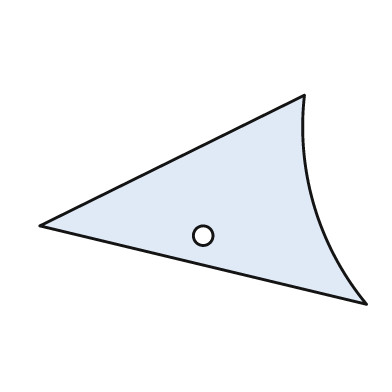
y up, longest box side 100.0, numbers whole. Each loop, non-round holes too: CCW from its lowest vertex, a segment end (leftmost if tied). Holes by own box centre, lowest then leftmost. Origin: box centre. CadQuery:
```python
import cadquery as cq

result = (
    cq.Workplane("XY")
    .moveTo(50.0, -32.0)
    .threePointArc((34.0, -2.0), (31.0, 32.0))
    .lineTo(-50.0, -8.0)
    .close()
    .moveTo(0.0, -11.0)
    .circle(3.0)
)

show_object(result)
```